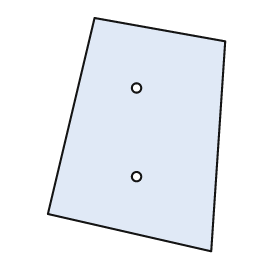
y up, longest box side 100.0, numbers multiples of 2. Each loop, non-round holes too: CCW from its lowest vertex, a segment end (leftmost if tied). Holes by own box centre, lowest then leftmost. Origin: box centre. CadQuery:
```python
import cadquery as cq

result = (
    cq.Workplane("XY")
    .moveTo(32.0, -50.0)
    .lineTo(38.0, 40.0)
    .lineTo(-18.0, 50.0)
    .lineTo(-38.0, -34.0)
    .close()
    .moveTo(0.0, -18.0)
    .circle(2.0)
    .moveTo(0.0, 20.0)
    .circle(2.0)
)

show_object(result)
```